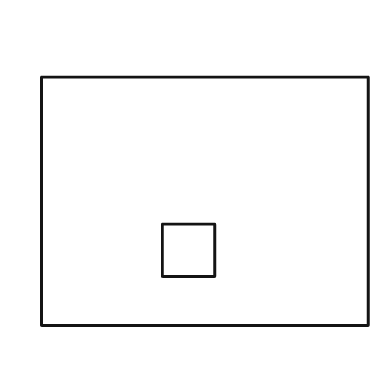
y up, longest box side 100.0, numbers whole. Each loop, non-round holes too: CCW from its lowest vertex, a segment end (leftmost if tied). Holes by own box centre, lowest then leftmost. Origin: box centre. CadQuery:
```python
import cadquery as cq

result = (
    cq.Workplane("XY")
    .moveTo(-50.0, -38.0)
    .lineTo(50.0, -38.0)
    .lineTo(50.0, 38.0)
    .lineTo(-50.0, 38.0)
    .close()
    .moveTo(-13.0, -23.0)
    .lineTo(3.0, -23.0)
    .lineTo(3.0, -7.0)
    .lineTo(-13.0, -7.0)
    .close()
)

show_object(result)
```